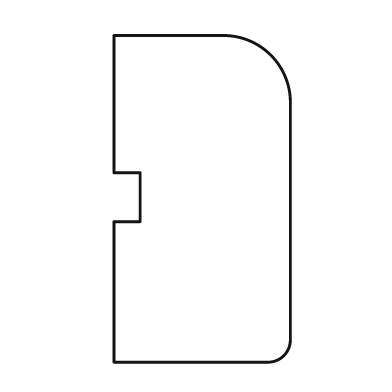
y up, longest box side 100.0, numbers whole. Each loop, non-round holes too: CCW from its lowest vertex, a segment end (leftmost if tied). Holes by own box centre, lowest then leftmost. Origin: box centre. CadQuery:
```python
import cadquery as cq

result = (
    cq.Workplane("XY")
    .moveTo(-27.0, -50.0)
    .lineTo(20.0, -50.0)
    .threePointArc((25.0, -48.0), (27.0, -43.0))
    .lineTo(27.0, 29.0)
    .threePointArc((21.0, 44.0), (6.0, 50.0))
    .lineTo(-27.0, 50.0)
    .lineTo(-27.0, 8.0)
    .lineTo(-19.0, 8.0)
    .lineTo(-19.0, -7.0)
    .lineTo(-27.0, -7.0)
    .close()
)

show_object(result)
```